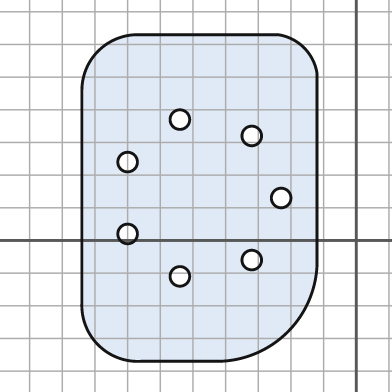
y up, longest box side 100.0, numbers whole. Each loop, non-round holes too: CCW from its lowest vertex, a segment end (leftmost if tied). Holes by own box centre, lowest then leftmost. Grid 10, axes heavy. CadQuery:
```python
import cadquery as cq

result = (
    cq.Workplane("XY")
    .moveTo(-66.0, -37.0)
    .lineTo(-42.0, -37.0)
    .threePointArc((-21.0, -28.0), (-12.0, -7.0))
    .lineTo(-12.0, 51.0)
    .threePointArc((-16.0, 59.0), (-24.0, 63.0))
    .lineTo(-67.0, 63.0)
    .threePointArc((-79.0, 58.0), (-84.0, 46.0))
    .lineTo(-84.0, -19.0)
    .threePointArc((-79.0, -32.0), (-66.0, -37.0))
    .close()
    .moveTo(-54.0, -11.0)
    .circle(3.0)
    .moveTo(-32.0, -6.0)
    .circle(3.0)
    .moveTo(-70.0, 2.0)
    .circle(3.0)
    .moveTo(-23.0, 13.0)
    .circle(3.0)
    .moveTo(-70.0, 24.0)
    .circle(3.0)
    .moveTo(-32.0, 32.0)
    .circle(3.0)
    .moveTo(-54.0, 37.0)
    .circle(3.0)
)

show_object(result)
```